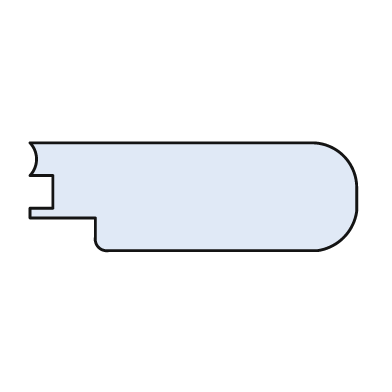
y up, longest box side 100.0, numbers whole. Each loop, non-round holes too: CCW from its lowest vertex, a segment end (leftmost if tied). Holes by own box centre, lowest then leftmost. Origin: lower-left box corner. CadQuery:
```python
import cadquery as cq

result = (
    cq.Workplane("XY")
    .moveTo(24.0, 0.0)
    .lineTo(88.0, 0.0)
    .threePointArc((96.0, 4.0), (100.0, 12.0))
    .lineTo(100.0, 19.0)
    .threePointArc((96.0, 29.0), (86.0, 33.0))
    .lineTo(0.0, 33.0)
    .threePointArc((2.0, 28.0), (0.0, 23.0))
    .lineTo(7.0, 23.0)
    .lineTo(7.0, 13.0)
    .lineTo(0.0, 13.0)
    .lineTo(0.0, 10.0)
    .lineTo(20.0, 10.0)
    .lineTo(20.0, 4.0)
    .threePointArc((21.0, 1.0), (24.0, 0.0))
    .close()
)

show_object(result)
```